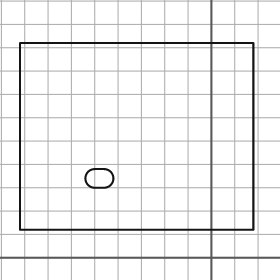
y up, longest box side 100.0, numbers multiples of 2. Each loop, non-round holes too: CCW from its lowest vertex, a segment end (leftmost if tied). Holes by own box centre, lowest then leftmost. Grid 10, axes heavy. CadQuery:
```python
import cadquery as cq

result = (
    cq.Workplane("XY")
    .moveTo(-82.0, 12.0)
    .lineTo(18.0, 12.0)
    .lineTo(18.0, 92.0)
    .lineTo(-82.0, 92.0)
    .close()
    .moveTo(-50.0, 30.0)
    .lineTo(-46.0, 30.0)
    .threePointArc((-42.0, 34.0), (-46.0, 38.0))
    .lineTo(-50.0, 38.0)
    .threePointArc((-54.0, 34.0), (-50.0, 30.0))
    .close()
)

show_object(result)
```